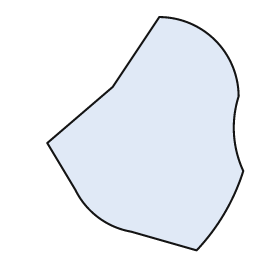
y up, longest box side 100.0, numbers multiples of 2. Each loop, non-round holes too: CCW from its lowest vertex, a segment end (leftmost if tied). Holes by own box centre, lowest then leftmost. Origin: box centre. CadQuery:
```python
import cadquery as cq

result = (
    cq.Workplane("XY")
    .moveTo(22.0, -50.0)
    .threePointArc((34.0, -34.0), (42.0, -16.0))
    .threePointArc((38.0, 0.0), (40.0, 16.0))
    .threePointArc((30.0, 40.0), (6.0, 50.0))
    .lineTo(-14.0, 20.0)
    .lineTo(-42.0, -4.0)
    .lineTo(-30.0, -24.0)
    .threePointArc((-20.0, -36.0), (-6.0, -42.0))
    .close()
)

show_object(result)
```